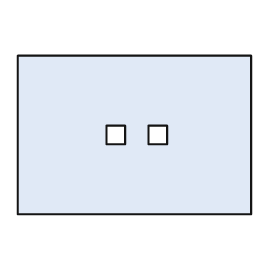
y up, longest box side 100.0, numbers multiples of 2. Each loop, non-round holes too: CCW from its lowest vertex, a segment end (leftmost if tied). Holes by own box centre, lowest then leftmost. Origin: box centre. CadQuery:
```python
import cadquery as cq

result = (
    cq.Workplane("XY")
    .moveTo(-50.0, -34.0)
    .lineTo(50.0, -34.0)
    .lineTo(50.0, 34.0)
    .lineTo(-50.0, 34.0)
    .close()
    .moveTo(-12.0, -4.0)
    .lineTo(-4.0, -4.0)
    .lineTo(-4.0, 4.0)
    .lineTo(-12.0, 4.0)
    .close()
    .moveTo(6.0, -4.0)
    .lineTo(14.0, -4.0)
    .lineTo(14.0, 4.0)
    .lineTo(6.0, 4.0)
    .close()
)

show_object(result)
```